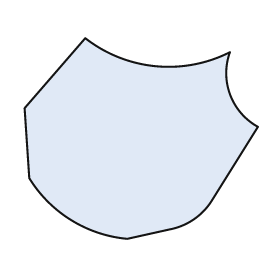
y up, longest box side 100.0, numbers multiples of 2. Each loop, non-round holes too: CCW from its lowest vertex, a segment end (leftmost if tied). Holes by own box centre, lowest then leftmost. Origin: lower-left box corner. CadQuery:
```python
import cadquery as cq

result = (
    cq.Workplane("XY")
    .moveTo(44.0, 0.0)
    .lineTo(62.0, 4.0)
    .threePointArc((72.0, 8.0), (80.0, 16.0))
    .lineTo(100.0, 48.0)
    .threePointArc((88.0, 62.0), (88.0, 80.0))
    .threePointArc((56.0, 74.0), (26.0, 86.0))
    .lineTo(0.0, 56.0)
    .lineTo(2.0, 26.0)
    .threePointArc((20.0, 8.0), (44.0, 0.0))
    .close()
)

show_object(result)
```